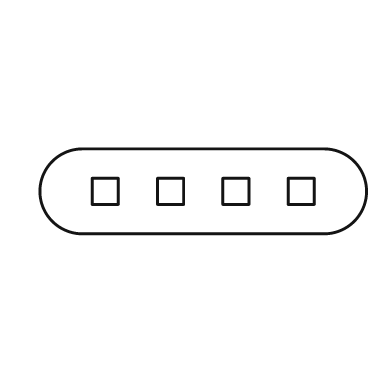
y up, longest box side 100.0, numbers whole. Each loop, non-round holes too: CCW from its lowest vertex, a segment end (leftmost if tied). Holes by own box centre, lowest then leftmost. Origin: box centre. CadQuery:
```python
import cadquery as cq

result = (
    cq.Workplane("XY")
    .moveTo(-37.0, -13.0)
    .lineTo(37.0, -13.0)
    .threePointArc((50.0, 0.0), (37.0, 13.0))
    .lineTo(-37.0, 13.0)
    .threePointArc((-50.0, 0.0), (-37.0, -13.0))
    .close()
    .moveTo(-34.0, -4.0)
    .lineTo(-26.0, -4.0)
    .lineTo(-26.0, 4.0)
    .lineTo(-34.0, 4.0)
    .close()
    .moveTo(-14.0, -4.0)
    .lineTo(-6.0, -4.0)
    .lineTo(-6.0, 4.0)
    .lineTo(-14.0, 4.0)
    .close()
    .moveTo(6.0, -4.0)
    .lineTo(14.0, -4.0)
    .lineTo(14.0, 4.0)
    .lineTo(6.0, 4.0)
    .close()
    .moveTo(26.0, -4.0)
    .lineTo(34.0, -4.0)
    .lineTo(34.0, 4.0)
    .lineTo(26.0, 4.0)
    .close()
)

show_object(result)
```